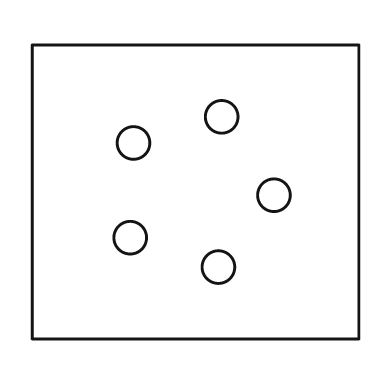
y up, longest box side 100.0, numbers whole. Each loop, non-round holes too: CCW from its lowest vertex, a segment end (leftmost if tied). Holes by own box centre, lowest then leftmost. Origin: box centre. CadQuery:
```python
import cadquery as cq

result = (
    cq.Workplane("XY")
    .moveTo(-50.0, -45.0)
    .lineTo(50.0, -45.0)
    .lineTo(50.0, 45.0)
    .lineTo(-50.0, 45.0)
    .close()
    .moveTo(7.0, -23.0)
    .circle(5.0)
    .moveTo(-20.0, -14.0)
    .circle(5.0)
    .moveTo(24.0, -1.0)
    .circle(5.0)
    .moveTo(-19.0, 15.0)
    .circle(5.0)
    .moveTo(8.0, 23.0)
    .circle(5.0)
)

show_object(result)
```